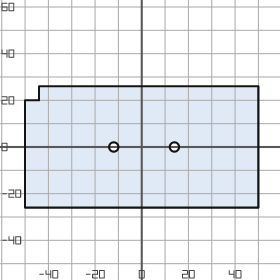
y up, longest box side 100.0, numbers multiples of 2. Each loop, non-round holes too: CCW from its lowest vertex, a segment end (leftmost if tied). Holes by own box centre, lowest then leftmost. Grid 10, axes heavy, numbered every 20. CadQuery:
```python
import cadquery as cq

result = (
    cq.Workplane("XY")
    .moveTo(-50.0, -26.0)
    .lineTo(50.0, -26.0)
    .lineTo(50.0, 26.0)
    .lineTo(-44.0, 26.0)
    .lineTo(-44.0, 20.0)
    .lineTo(-50.0, 20.0)
    .close()
    .moveTo(-12.0, 0.0)
    .circle(2.0)
    .moveTo(14.0, 0.0)
    .circle(2.0)
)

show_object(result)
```